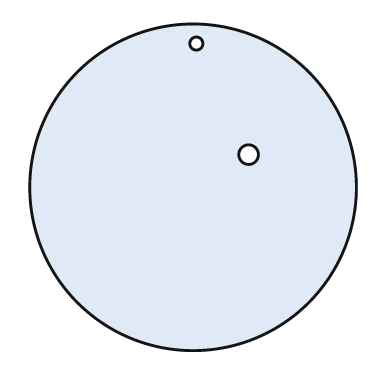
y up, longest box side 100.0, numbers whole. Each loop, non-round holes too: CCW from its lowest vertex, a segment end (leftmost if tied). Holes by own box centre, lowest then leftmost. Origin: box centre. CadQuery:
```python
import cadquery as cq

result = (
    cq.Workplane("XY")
    .moveTo(0.0, 0.0)
    .circle(50.0)
    .moveTo(17.0, 10.0)
    .circle(3.0)
    .moveTo(1.0, 44.0)
    .circle(2.0)
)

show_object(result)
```